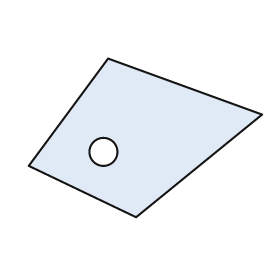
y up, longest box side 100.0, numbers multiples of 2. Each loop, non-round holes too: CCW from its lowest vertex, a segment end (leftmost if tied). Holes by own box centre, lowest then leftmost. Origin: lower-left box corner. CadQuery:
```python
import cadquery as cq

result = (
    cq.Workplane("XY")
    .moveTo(46.0, 0.0)
    .lineTo(100.0, 44.0)
    .lineTo(34.0, 68.0)
    .lineTo(0.0, 22.0)
    .close()
    .moveTo(32.0, 28.0)
    .circle(6.0)
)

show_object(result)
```